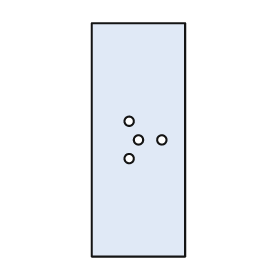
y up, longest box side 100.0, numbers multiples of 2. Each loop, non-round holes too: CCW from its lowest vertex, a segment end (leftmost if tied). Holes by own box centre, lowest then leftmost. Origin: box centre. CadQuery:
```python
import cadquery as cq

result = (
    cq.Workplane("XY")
    .moveTo(-20.0, -50.0)
    .lineTo(20.0, -50.0)
    .lineTo(20.0, 50.0)
    .lineTo(-20.0, 50.0)
    .close()
    .moveTo(-4.0, -8.0)
    .circle(2.0)
    .moveTo(0.0, 0.0)
    .circle(2.0)
    .moveTo(10.0, 0.0)
    .circle(2.0)
    .moveTo(-4.0, 8.0)
    .circle(2.0)
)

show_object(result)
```